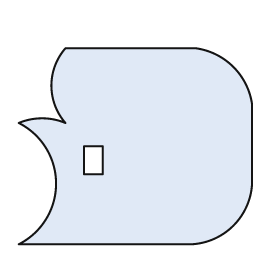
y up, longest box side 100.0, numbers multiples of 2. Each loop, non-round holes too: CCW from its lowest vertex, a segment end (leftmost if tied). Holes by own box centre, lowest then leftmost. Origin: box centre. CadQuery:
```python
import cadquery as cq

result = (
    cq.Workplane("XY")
    .moveTo(-50.0, -42.0)
    .lineTo(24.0, -42.0)
    .threePointArc((42.0, -34.0), (50.0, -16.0))
    .lineTo(50.0, 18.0)
    .threePointArc((42.0, 34.0), (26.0, 42.0))
    .lineTo(-30.0, 42.0)
    .threePointArc((-36.0, 26.0), (-30.0, 10.0))
    .threePointArc((-40.0, 12.0), (-50.0, 10.0))
    .threePointArc((-34.0, -16.0), (-50.0, -42.0))
    .close()
    .moveTo(-22.0, -12.0)
    .lineTo(-14.0, -12.0)
    .lineTo(-14.0, 0.0)
    .lineTo(-22.0, 0.0)
    .close()
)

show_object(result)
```